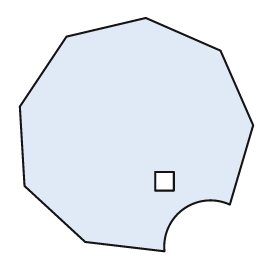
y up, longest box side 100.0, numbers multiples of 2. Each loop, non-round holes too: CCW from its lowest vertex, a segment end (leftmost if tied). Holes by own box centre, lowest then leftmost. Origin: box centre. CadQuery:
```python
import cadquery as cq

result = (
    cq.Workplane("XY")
    .moveTo(12.0, -50.0)
    .threePointArc((20.0, -32.0), (40.0, -30.0))
    .lineTo(50.0, 4.0)
    .lineTo(36.0, 36.0)
    .lineTo(4.0, 50.0)
    .lineTo(-30.0, 42.0)
    .lineTo(-50.0, 12.0)
    .lineTo(-48.0, -22.0)
    .lineTo(-22.0, -46.0)
    .close()
    .moveTo(8.0, -24.0)
    .lineTo(16.0, -24.0)
    .lineTo(16.0, -16.0)
    .lineTo(8.0, -16.0)
    .close()
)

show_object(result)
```